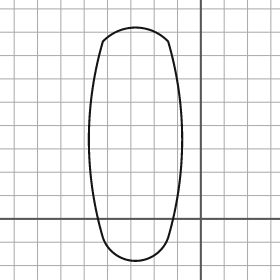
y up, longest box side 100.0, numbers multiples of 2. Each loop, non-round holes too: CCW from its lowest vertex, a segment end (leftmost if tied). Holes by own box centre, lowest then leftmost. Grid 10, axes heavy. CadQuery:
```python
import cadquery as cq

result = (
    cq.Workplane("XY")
    .moveTo(-42.0, -8.0)
    .threePointArc((-28.0, -18.0), (-14.0, -8.0))
    .threePointArc((-8.0, 34.0), (-14.0, 76.0))
    .threePointArc((-28.0, 82.0), (-42.0, 76.0))
    .threePointArc((-48.0, 34.0), (-42.0, -8.0))
    .close()
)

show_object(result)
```